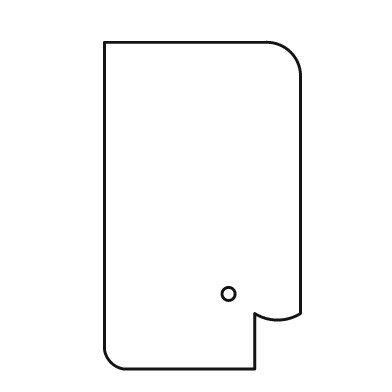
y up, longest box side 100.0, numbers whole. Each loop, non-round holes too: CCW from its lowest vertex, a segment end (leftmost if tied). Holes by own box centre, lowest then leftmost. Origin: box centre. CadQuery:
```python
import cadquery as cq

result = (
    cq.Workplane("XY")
    .moveTo(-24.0, -50.0)
    .lineTo(16.0, -50.0)
    .lineTo(16.0, -33.0)
    .threePointArc((23.0, -35.0), (30.0, -33.0))
    .lineTo(30.0, 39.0)
    .threePointArc((27.0, 47.0), (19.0, 50.0))
    .lineTo(-30.0, 50.0)
    .lineTo(-30.0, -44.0)
    .threePointArc((-28.0, -48.0), (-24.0, -50.0))
    .close()
    .moveTo(8.0, -27.0)
    .circle(2.0)
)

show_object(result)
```